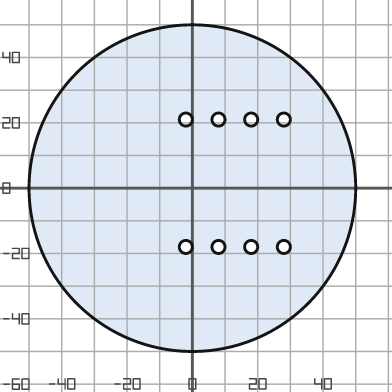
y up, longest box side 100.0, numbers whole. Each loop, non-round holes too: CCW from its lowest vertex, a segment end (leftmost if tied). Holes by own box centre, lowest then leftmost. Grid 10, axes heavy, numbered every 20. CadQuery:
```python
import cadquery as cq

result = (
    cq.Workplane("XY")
    .moveTo(0.0, 0.0)
    .circle(50.0)
    .moveTo(-2.0, -18.0)
    .circle(2.0)
    .moveTo(8.0, -18.0)
    .circle(2.0)
    .moveTo(18.0, -18.0)
    .circle(2.0)
    .moveTo(28.0, -18.0)
    .circle(2.0)
    .moveTo(-2.0, 21.0)
    .circle(2.0)
    .moveTo(8.0, 21.0)
    .circle(2.0)
    .moveTo(18.0, 21.0)
    .circle(2.0)
    .moveTo(28.0, 21.0)
    .circle(2.0)
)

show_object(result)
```